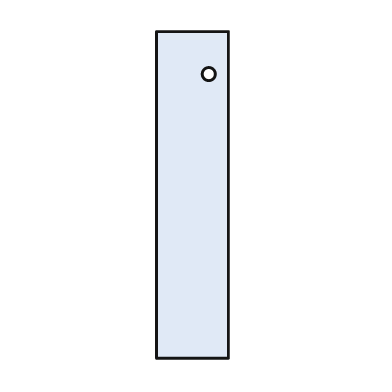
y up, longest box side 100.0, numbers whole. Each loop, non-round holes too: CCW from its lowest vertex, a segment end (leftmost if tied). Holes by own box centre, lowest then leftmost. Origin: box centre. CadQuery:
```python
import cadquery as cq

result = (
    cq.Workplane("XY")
    .moveTo(-11.0, -50.0)
    .lineTo(11.0, -50.0)
    .lineTo(11.0, 50.0)
    .lineTo(-11.0, 50.0)
    .close()
    .moveTo(5.0, 37.0)
    .circle(2.0)
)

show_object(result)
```